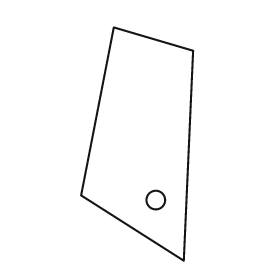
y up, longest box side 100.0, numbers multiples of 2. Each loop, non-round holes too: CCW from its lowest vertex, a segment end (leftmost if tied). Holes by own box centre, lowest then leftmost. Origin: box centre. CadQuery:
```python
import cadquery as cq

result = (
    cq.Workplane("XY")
    .moveTo(20.0, -50.0)
    .lineTo(24.0, 40.0)
    .lineTo(-10.0, 50.0)
    .lineTo(-24.0, -22.0)
    .close()
    .moveTo(8.0, -24.0)
    .circle(4.0)
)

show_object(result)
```